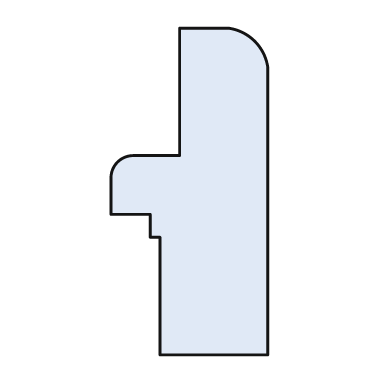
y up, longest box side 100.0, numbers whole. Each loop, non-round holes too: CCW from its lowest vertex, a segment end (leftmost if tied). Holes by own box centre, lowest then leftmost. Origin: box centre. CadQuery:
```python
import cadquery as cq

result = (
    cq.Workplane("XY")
    .moveTo(-9.0, -50.0)
    .lineTo(24.0, -50.0)
    .lineTo(24.0, 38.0)
    .threePointArc((20.0, 46.0), (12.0, 50.0))
    .lineTo(-3.0, 50.0)
    .lineTo(-3.0, 11.0)
    .lineTo(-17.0, 11.0)
    .threePointArc((-22.0, 9.0), (-24.0, 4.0))
    .lineTo(-24.0, -7.0)
    .lineTo(-12.0, -7.0)
    .lineTo(-12.0, -14.0)
    .lineTo(-9.0, -14.0)
    .close()
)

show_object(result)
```